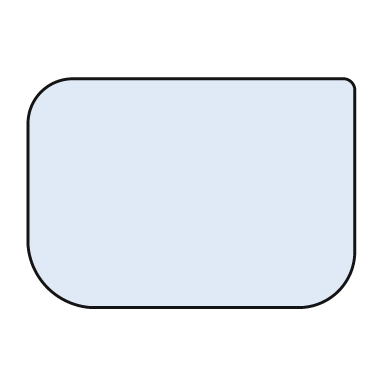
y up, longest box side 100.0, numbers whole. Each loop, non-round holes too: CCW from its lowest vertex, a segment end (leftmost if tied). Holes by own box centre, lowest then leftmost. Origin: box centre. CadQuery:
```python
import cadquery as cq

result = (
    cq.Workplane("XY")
    .moveTo(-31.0, -35.0)
    .lineTo(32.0, -35.0)
    .threePointArc((45.0, -30.0), (50.0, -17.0))
    .lineTo(50.0, 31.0)
    .threePointArc((49.0, 34.0), (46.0, 35.0))
    .lineTo(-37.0, 35.0)
    .threePointArc((-46.0, 31.0), (-50.0, 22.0))
    .lineTo(-50.0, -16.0)
    .threePointArc((-44.0, -29.0), (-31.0, -35.0))
    .close()
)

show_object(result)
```